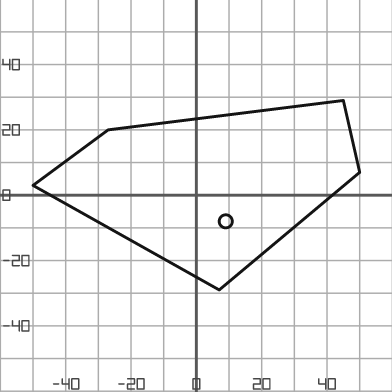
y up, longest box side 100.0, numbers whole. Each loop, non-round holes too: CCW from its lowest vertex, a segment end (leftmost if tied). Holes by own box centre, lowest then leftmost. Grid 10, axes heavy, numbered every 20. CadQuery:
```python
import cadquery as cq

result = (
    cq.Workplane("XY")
    .moveTo(7.0, -29.0)
    .lineTo(50.0, 7.0)
    .lineTo(45.0, 29.0)
    .lineTo(-27.0, 20.0)
    .lineTo(-50.0, 3.0)
    .close()
    .moveTo(9.0, -8.0)
    .circle(2.0)
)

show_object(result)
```